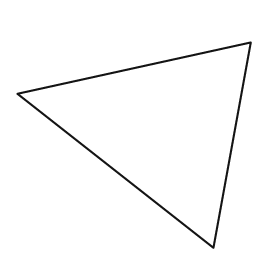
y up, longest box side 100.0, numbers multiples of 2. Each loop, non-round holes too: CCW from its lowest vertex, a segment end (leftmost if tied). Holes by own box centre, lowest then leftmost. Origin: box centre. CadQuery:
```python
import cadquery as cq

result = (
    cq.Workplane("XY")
    .moveTo(34.0, -44.0)
    .lineTo(50.0, 44.0)
    .lineTo(-50.0, 22.0)
    .close()
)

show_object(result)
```